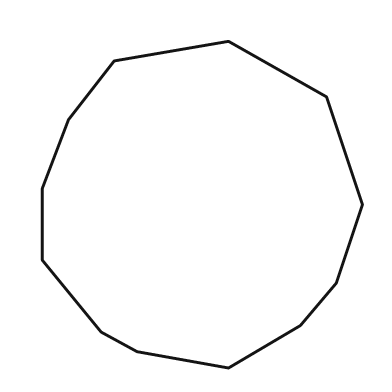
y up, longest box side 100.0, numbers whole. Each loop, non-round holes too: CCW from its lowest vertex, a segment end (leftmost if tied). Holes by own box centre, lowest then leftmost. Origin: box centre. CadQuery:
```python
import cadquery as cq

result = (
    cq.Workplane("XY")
    .moveTo(8.0, -50.0)
    .lineTo(30.0, -37.0)
    .lineTo(41.0, -24.0)
    .lineTo(49.0, 0.0)
    .lineTo(38.0, 33.0)
    .lineTo(8.0, 50.0)
    .lineTo(-27.0, 44.0)
    .lineTo(-41.0, 26.0)
    .lineTo(-49.0, 5.0)
    .lineTo(-49.0, -17.0)
    .lineTo(-31.0, -39.0)
    .lineTo(-20.0, -45.0)
    .close()
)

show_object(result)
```